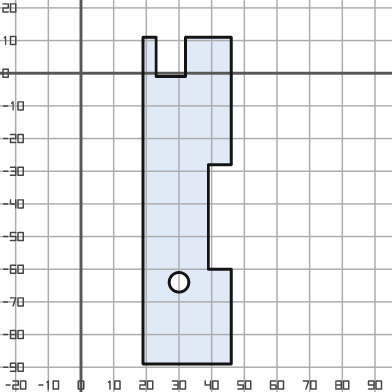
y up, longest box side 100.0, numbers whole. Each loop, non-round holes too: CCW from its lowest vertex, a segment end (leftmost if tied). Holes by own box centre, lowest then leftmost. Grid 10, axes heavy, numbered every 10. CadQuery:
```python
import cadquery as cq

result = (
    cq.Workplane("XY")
    .moveTo(19.0, -89.0)
    .lineTo(46.0, -89.0)
    .lineTo(46.0, -60.0)
    .lineTo(39.0, -60.0)
    .lineTo(39.0, -28.0)
    .lineTo(46.0, -28.0)
    .lineTo(46.0, 11.0)
    .lineTo(32.0, 11.0)
    .lineTo(32.0, -1.0)
    .lineTo(23.0, -1.0)
    .lineTo(23.0, 11.0)
    .lineTo(19.0, 11.0)
    .close()
    .moveTo(30.0, -64.0)
    .circle(3.0)
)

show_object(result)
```